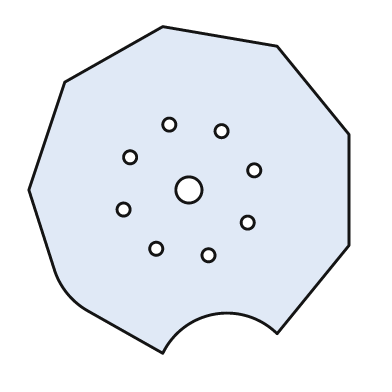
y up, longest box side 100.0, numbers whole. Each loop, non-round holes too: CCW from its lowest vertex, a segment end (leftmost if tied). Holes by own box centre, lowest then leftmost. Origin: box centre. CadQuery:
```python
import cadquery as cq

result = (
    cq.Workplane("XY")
    .moveTo(-8.0, -50.0)
    .threePointArc((8.0, -38.0), (27.0, -44.0))
    .lineTo(49.0, -17.0)
    .lineTo(49.0, 17.0)
    .lineTo(27.0, 44.0)
    .lineTo(-8.0, 50.0)
    .lineTo(-38.0, 33.0)
    .lineTo(-49.0, 0.0)
    .lineTo(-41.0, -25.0)
    .threePointArc((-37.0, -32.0), (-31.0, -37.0))
    .close()
    .moveTo(6.0, -20.0)
    .circle(2.0)
    .moveTo(-10.0, -18.0)
    .circle(2.0)
    .moveTo(18.0, -10.0)
    .circle(2.0)
    .moveTo(-20.0, -6.0)
    .circle(2.0)
    .moveTo(0.0, 0.0)
    .circle(4.0)
    .moveTo(20.0, 6.0)
    .circle(2.0)
    .moveTo(-18.0, 10.0)
    .circle(2.0)
    .moveTo(10.0, 18.0)
    .circle(2.0)
    .moveTo(-6.0, 20.0)
    .circle(2.0)
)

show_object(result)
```